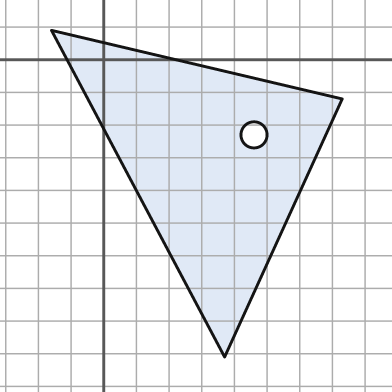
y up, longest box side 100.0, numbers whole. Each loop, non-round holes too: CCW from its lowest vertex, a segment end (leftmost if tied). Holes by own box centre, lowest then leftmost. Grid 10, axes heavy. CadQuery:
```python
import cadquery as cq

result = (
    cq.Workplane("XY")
    .moveTo(37.0, -91.0)
    .lineTo(73.0, -12.0)
    .lineTo(-16.0, 9.0)
    .close()
    .moveTo(46.0, -23.0)
    .circle(4.0)
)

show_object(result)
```